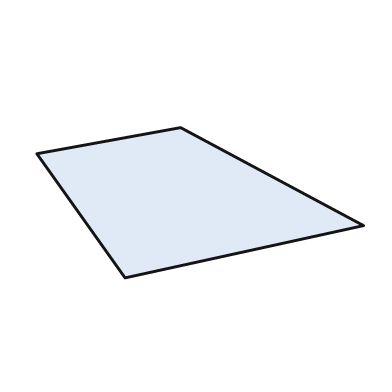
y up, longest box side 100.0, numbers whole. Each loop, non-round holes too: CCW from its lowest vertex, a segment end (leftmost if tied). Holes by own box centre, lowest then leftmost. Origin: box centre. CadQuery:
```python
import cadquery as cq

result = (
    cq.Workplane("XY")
    .moveTo(-23.0, -23.0)
    .lineTo(50.0, -7.0)
    .lineTo(-6.0, 23.0)
    .lineTo(-50.0, 15.0)
    .close()
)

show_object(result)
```